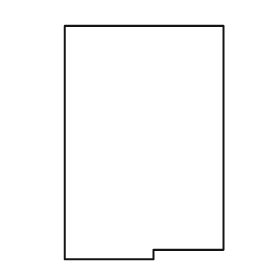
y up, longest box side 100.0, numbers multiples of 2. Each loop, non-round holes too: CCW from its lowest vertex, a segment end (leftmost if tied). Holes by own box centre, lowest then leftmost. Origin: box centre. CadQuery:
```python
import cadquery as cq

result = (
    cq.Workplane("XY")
    .moveTo(-34.0, -50.0)
    .lineTo(4.0, -50.0)
    .lineTo(4.0, -46.0)
    .lineTo(34.0, -46.0)
    .lineTo(34.0, 50.0)
    .lineTo(-34.0, 50.0)
    .close()
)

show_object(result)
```